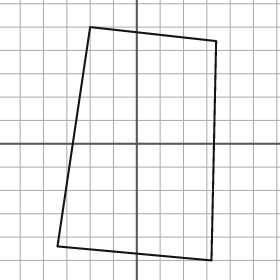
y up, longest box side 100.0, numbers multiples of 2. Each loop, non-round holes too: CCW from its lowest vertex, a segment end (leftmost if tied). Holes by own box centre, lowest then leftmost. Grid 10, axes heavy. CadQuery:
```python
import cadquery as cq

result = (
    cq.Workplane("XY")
    .moveTo(32.0, -50.0)
    .lineTo(34.0, 44.0)
    .lineTo(-20.0, 50.0)
    .lineTo(-34.0, -44.0)
    .close()
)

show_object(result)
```